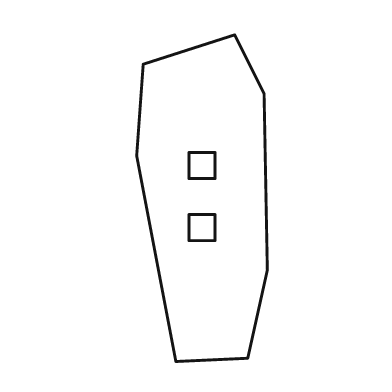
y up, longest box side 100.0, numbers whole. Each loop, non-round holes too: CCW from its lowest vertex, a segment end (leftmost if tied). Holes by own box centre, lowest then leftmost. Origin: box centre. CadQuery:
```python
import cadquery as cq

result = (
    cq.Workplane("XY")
    .moveTo(-8.0, -50.0)
    .lineTo(14.0, -49.0)
    .lineTo(20.0, -22.0)
    .lineTo(19.0, 32.0)
    .lineTo(10.0, 50.0)
    .lineTo(-18.0, 41.0)
    .lineTo(-20.0, 13.0)
    .close()
    .moveTo(-4.0, -13.0)
    .lineTo(4.0, -13.0)
    .lineTo(4.0, -5.0)
    .lineTo(-4.0, -5.0)
    .close()
    .moveTo(-4.0, 6.0)
    .lineTo(4.0, 6.0)
    .lineTo(4.0, 14.0)
    .lineTo(-4.0, 14.0)
    .close()
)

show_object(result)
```